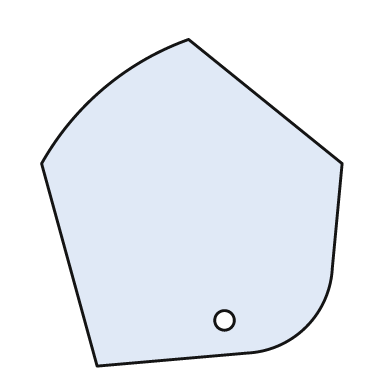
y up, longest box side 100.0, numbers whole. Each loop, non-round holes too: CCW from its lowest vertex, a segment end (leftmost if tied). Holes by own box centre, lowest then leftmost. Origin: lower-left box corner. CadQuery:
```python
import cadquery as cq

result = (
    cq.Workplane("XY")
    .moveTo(17.0, 0.0)
    .lineTo(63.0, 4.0)
    .threePointArc((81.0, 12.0), (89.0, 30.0))
    .lineTo(92.0, 62.0)
    .lineTo(45.0, 100.0)
    .threePointArc((19.0, 85.0), (0.0, 62.0))
    .close()
    .moveTo(56.0, 14.0)
    .circle(3.0)
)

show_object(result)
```